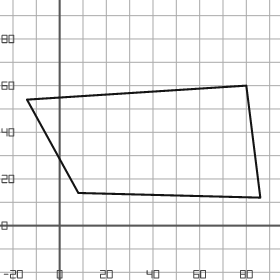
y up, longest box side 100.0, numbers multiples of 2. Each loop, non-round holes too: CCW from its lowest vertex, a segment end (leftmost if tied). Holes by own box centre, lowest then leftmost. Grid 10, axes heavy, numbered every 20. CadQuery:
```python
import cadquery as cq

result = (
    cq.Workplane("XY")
    .moveTo(86.0, 12.0)
    .lineTo(80.0, 60.0)
    .lineTo(-14.0, 54.0)
    .lineTo(8.0, 14.0)
    .close()
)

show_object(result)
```